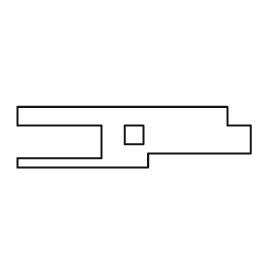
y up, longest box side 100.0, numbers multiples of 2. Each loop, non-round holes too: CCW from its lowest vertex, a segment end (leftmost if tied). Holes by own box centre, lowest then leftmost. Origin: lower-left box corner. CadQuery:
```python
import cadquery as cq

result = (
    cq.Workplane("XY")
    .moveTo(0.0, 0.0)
    .lineTo(56.0, 0.0)
    .lineTo(56.0, 6.0)
    .lineTo(100.0, 6.0)
    .lineTo(100.0, 18.0)
    .lineTo(90.0, 18.0)
    .lineTo(90.0, 26.0)
    .lineTo(0.0, 26.0)
    .lineTo(0.0, 18.0)
    .lineTo(36.0, 18.0)
    .lineTo(36.0, 4.0)
    .lineTo(0.0, 4.0)
    .close()
    .moveTo(46.0, 10.0)
    .lineTo(54.0, 10.0)
    .lineTo(54.0, 18.0)
    .lineTo(46.0, 18.0)
    .close()
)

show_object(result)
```